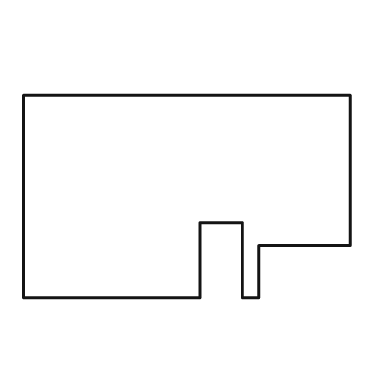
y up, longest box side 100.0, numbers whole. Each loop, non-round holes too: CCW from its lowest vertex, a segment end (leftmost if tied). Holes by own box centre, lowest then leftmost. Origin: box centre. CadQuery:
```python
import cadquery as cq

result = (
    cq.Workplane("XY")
    .moveTo(-50.0, -31.0)
    .lineTo(4.0, -31.0)
    .lineTo(4.0, -8.0)
    .lineTo(17.0, -8.0)
    .lineTo(17.0, -31.0)
    .lineTo(22.0, -31.0)
    .lineTo(22.0, -15.0)
    .lineTo(50.0, -15.0)
    .lineTo(50.0, 31.0)
    .lineTo(-50.0, 31.0)
    .close()
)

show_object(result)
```